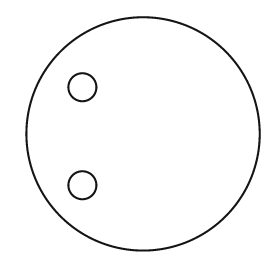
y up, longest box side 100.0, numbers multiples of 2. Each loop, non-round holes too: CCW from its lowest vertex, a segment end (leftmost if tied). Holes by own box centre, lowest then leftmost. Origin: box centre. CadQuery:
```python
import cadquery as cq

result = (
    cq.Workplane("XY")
    .moveTo(0.0, 0.0)
    .circle(50.0)
    .moveTo(-26.0, -22.0)
    .circle(6.0)
    .moveTo(-26.0, 20.0)
    .circle(6.0)
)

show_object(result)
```